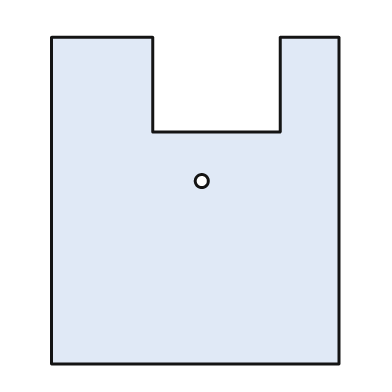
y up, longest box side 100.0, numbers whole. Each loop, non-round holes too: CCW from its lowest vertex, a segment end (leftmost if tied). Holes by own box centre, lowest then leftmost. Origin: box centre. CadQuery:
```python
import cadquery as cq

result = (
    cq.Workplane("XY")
    .moveTo(-44.0, -50.0)
    .lineTo(44.0, -50.0)
    .lineTo(44.0, 50.0)
    .lineTo(26.0, 50.0)
    .lineTo(26.0, 21.0)
    .lineTo(-13.0, 21.0)
    .lineTo(-13.0, 50.0)
    .lineTo(-44.0, 50.0)
    .close()
    .moveTo(2.0, 6.0)
    .circle(2.0)
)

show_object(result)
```